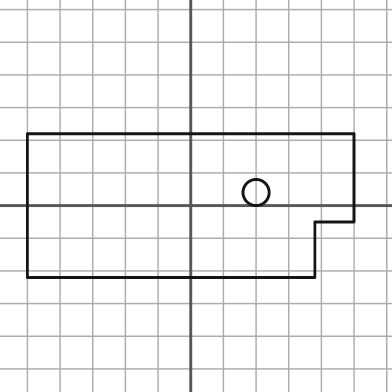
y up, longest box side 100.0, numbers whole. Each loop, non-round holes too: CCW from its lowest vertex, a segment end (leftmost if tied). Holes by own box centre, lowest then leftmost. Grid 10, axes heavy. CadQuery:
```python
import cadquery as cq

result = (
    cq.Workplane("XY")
    .moveTo(-50.0, -22.0)
    .lineTo(38.0, -22.0)
    .lineTo(38.0, -5.0)
    .lineTo(50.0, -5.0)
    .lineTo(50.0, 22.0)
    .lineTo(-50.0, 22.0)
    .close()
    .moveTo(20.0, 4.0)
    .circle(4.0)
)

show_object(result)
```